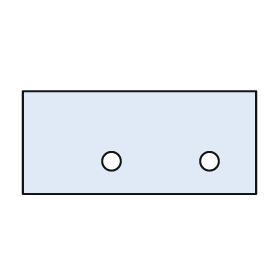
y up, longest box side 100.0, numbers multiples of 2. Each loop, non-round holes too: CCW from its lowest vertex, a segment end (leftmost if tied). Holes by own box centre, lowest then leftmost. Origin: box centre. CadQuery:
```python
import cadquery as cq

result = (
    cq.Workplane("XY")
    .moveTo(-50.0, -22.0)
    .lineTo(50.0, -22.0)
    .lineTo(50.0, 22.0)
    .lineTo(-50.0, 22.0)
    .close()
    .moveTo(-12.0, -8.0)
    .circle(4.0)
    .moveTo(30.0, -8.0)
    .circle(4.0)
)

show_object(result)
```